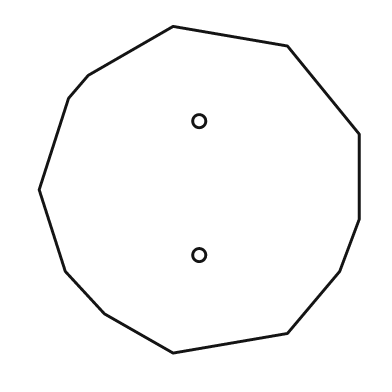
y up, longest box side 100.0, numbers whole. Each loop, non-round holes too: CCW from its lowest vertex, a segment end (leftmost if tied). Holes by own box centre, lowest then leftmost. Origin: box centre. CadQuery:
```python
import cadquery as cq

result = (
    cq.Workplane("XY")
    .moveTo(-8.0, -50.0)
    .lineTo(27.0, -44.0)
    .lineTo(43.0, -25.0)
    .lineTo(49.0, -9.0)
    .lineTo(49.0, 17.0)
    .lineTo(27.0, 44.0)
    .lineTo(-8.0, 50.0)
    .lineTo(-34.0, 35.0)
    .lineTo(-40.0, 28.0)
    .lineTo(-49.0, 0.0)
    .lineTo(-41.0, -25.0)
    .lineTo(-29.0, -38.0)
    .close()
    .moveTo(0.0, -20.0)
    .circle(2.0)
    .moveTo(0.0, 21.0)
    .circle(2.0)
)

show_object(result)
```